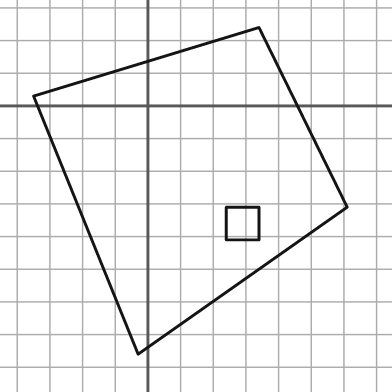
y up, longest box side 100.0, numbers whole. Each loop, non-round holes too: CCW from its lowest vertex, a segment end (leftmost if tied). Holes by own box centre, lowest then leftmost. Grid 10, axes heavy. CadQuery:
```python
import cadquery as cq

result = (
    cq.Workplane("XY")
    .moveTo(-3.0, -76.0)
    .lineTo(61.0, -31.0)
    .lineTo(34.0, 24.0)
    .lineTo(-35.0, 3.0)
    .close()
    .moveTo(24.0, -41.0)
    .lineTo(34.0, -41.0)
    .lineTo(34.0, -31.0)
    .lineTo(24.0, -31.0)
    .close()
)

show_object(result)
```